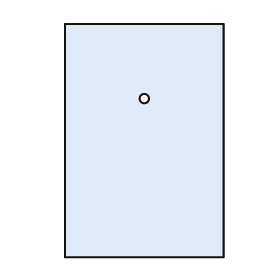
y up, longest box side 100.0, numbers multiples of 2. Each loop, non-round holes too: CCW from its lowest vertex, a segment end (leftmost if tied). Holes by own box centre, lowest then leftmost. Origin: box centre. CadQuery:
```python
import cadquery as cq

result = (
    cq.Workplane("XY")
    .moveTo(-34.0, -50.0)
    .lineTo(34.0, -50.0)
    .lineTo(34.0, 50.0)
    .lineTo(-34.0, 50.0)
    .close()
    .moveTo(0.0, 18.0)
    .circle(2.0)
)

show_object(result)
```